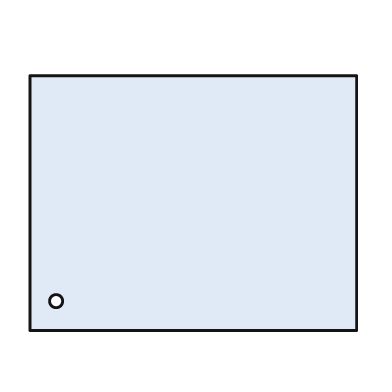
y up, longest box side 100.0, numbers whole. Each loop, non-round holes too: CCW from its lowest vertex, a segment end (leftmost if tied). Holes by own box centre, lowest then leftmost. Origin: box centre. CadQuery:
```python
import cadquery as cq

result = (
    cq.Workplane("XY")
    .moveTo(-50.0, -39.0)
    .lineTo(50.0, -39.0)
    .lineTo(50.0, 39.0)
    .lineTo(-50.0, 39.0)
    .close()
    .moveTo(-42.0, -30.0)
    .circle(2.0)
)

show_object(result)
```